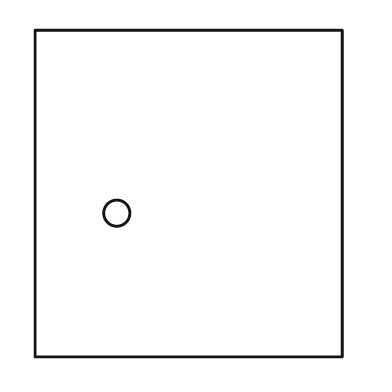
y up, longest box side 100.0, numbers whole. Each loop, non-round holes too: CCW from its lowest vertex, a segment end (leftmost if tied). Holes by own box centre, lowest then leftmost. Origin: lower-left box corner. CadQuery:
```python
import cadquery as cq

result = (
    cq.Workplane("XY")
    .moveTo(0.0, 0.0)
    .lineTo(94.0, 0.0)
    .lineTo(94.0, 100.0)
    .lineTo(0.0, 100.0)
    .close()
    .moveTo(25.0, 44.0)
    .circle(4.0)
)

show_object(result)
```